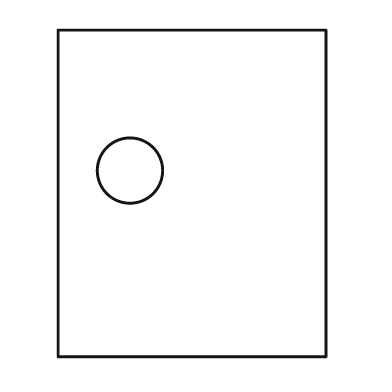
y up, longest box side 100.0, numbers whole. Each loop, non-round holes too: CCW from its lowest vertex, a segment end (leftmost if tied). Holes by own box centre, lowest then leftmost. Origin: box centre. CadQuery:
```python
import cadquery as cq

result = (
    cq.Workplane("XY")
    .moveTo(-41.0, -50.0)
    .lineTo(41.0, -50.0)
    .lineTo(41.0, 50.0)
    .lineTo(-41.0, 50.0)
    .close()
    .moveTo(-19.0, 7.0)
    .circle(10.0)
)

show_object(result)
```